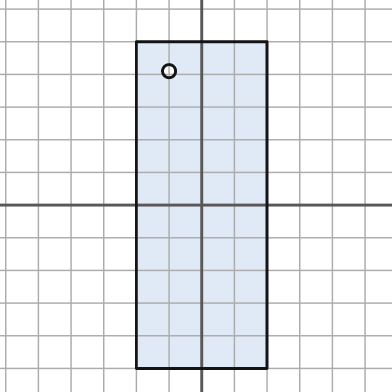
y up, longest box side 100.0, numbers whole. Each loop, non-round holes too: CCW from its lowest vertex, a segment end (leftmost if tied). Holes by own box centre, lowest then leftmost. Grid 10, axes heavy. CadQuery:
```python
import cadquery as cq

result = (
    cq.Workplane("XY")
    .moveTo(-20.0, -50.0)
    .lineTo(20.0, -50.0)
    .lineTo(20.0, 50.0)
    .lineTo(-20.0, 50.0)
    .close()
    .moveTo(-10.0, 41.0)
    .circle(2.0)
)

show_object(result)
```